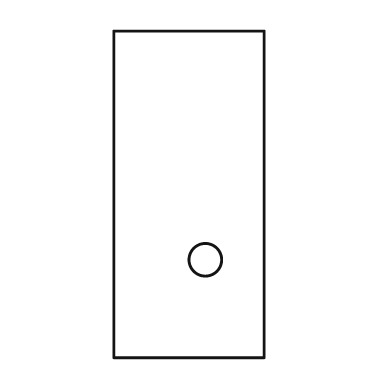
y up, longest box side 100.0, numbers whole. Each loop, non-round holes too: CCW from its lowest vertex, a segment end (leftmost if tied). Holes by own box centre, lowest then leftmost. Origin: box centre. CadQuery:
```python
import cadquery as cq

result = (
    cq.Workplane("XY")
    .moveTo(-23.0, -50.0)
    .lineTo(23.0, -50.0)
    .lineTo(23.0, 50.0)
    .lineTo(-23.0, 50.0)
    .close()
    .moveTo(5.0, -20.0)
    .circle(5.0)
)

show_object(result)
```